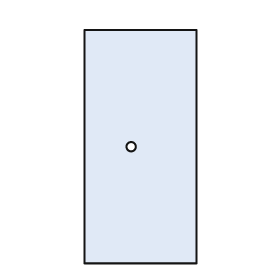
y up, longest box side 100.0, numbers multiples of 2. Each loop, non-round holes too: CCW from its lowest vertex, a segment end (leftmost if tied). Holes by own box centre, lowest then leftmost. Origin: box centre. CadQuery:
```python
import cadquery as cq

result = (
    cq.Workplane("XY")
    .moveTo(-24.0, -50.0)
    .lineTo(24.0, -50.0)
    .lineTo(24.0, 50.0)
    .lineTo(-24.0, 50.0)
    .close()
    .moveTo(-4.0, 0.0)
    .circle(2.0)
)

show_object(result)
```